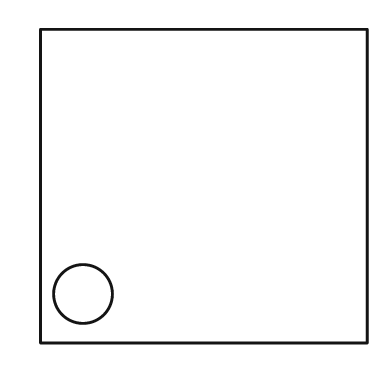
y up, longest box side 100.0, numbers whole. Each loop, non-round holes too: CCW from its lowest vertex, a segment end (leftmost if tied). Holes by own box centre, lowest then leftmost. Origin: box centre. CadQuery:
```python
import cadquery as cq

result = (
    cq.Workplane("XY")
    .moveTo(-50.0, -48.0)
    .lineTo(50.0, -48.0)
    .lineTo(50.0, 48.0)
    .lineTo(-50.0, 48.0)
    .close()
    .moveTo(-37.0, -33.0)
    .circle(9.0)
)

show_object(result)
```